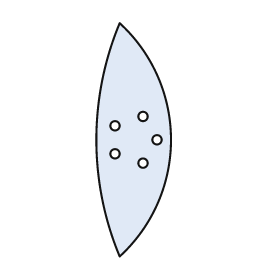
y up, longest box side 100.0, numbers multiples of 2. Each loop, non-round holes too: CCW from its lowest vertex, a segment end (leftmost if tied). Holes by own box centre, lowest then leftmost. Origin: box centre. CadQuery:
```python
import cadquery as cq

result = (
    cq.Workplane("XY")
    .moveTo(-6.0, -50.0)
    .threePointArc((16.0, 0.0), (-6.0, 50.0))
    .threePointArc((-16.0, 0.0), (-6.0, -50.0))
    .close()
    .moveTo(4.0, -10.0)
    .circle(2.0)
    .moveTo(-8.0, -6.0)
    .circle(2.0)
    .moveTo(10.0, 0.0)
    .circle(2.0)
    .moveTo(-8.0, 6.0)
    .circle(2.0)
    .moveTo(4.0, 10.0)
    .circle(2.0)
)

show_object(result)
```